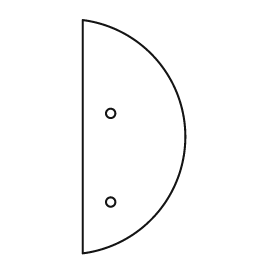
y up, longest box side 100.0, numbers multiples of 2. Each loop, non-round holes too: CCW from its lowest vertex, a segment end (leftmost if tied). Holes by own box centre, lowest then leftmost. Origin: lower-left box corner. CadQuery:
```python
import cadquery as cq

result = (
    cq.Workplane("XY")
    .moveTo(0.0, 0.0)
    .threePointArc((44.0, 50.0), (0.0, 100.0))
    .close()
    .moveTo(12.0, 22.0)
    .circle(2.0)
    .moveTo(12.0, 60.0)
    .circle(2.0)
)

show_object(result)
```